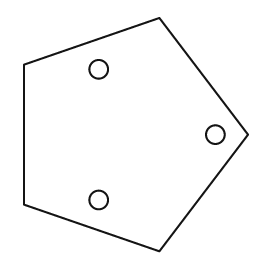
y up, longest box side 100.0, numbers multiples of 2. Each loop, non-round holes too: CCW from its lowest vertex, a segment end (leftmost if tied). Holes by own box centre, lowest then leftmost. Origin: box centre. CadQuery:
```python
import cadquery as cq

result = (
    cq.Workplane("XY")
    .moveTo(10.0, -50.0)
    .lineTo(48.0, 0.0)
    .lineTo(10.0, 50.0)
    .lineTo(-48.0, 30.0)
    .lineTo(-48.0, -30.0)
    .close()
    .moveTo(-16.0, -28.0)
    .circle(4.0)
    .moveTo(34.0, 0.0)
    .circle(4.0)
    .moveTo(-16.0, 28.0)
    .circle(4.0)
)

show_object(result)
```